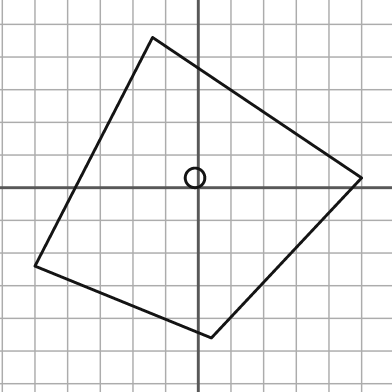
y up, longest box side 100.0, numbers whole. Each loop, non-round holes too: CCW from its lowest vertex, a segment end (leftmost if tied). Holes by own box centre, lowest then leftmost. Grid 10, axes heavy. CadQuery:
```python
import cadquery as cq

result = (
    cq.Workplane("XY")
    .moveTo(4.0, -46.0)
    .lineTo(50.0, 3.0)
    .lineTo(-14.0, 46.0)
    .lineTo(-50.0, -24.0)
    .close()
    .moveTo(-1.0, 3.0)
    .circle(3.0)
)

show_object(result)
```